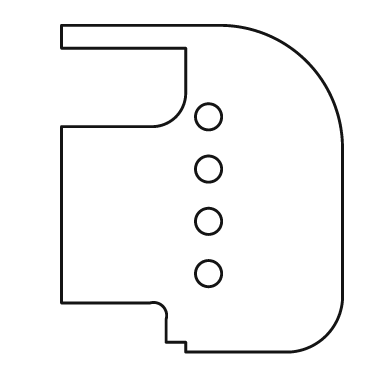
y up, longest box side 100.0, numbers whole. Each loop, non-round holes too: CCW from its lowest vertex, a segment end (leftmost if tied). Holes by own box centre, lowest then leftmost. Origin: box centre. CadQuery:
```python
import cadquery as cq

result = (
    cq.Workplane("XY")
    .moveTo(-5.0, -50.0)
    .lineTo(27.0, -50.0)
    .threePointArc((38.0, -45.0), (43.0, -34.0))
    .lineTo(43.0, 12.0)
    .threePointArc((32.0, 39.0), (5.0, 50.0))
    .lineTo(-43.0, 50.0)
    .lineTo(-43.0, 43.0)
    .lineTo(-5.0, 43.0)
    .lineTo(-5.0, 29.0)
    .threePointArc((-8.0, 22.0), (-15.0, 19.0))
    .lineTo(-43.0, 19.0)
    .lineTo(-43.0, -35.0)
    .lineTo(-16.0, -35.0)
    .threePointArc((-12.0, -36.0), (-11.0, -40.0))
    .lineTo(-11.0, -47.0)
    .lineTo(-5.0, -47.0)
    .close()
    .moveTo(2.0, -26.0)
    .circle(4.0)
    .moveTo(2.0, -10.0)
    .circle(4.0)
    .moveTo(2.0, 6.0)
    .circle(4.0)
    .moveTo(2.0, 22.0)
    .circle(4.0)
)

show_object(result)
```